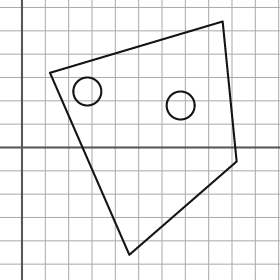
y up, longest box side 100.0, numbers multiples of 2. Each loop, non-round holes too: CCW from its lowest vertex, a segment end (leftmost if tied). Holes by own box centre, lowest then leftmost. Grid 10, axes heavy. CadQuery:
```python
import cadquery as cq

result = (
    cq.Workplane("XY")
    .moveTo(46.0, -46.0)
    .lineTo(92.0, -6.0)
    .lineTo(86.0, 54.0)
    .lineTo(12.0, 32.0)
    .close()
    .moveTo(68.0, 18.0)
    .circle(6.0)
    .moveTo(28.0, 24.0)
    .circle(6.0)
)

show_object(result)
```